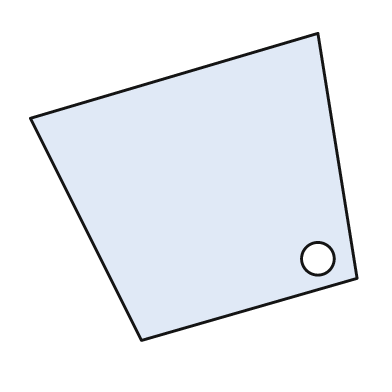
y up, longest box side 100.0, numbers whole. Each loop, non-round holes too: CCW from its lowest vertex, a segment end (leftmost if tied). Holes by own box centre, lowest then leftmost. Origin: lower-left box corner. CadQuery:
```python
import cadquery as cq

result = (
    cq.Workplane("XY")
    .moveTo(34.0, 0.0)
    .lineTo(100.0, 19.0)
    .lineTo(88.0, 94.0)
    .lineTo(0.0, 68.0)
    .close()
    .moveTo(88.0, 25.0)
    .circle(5.0)
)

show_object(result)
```